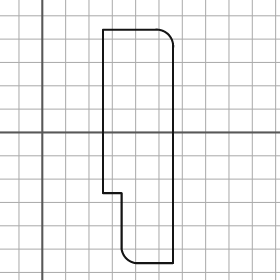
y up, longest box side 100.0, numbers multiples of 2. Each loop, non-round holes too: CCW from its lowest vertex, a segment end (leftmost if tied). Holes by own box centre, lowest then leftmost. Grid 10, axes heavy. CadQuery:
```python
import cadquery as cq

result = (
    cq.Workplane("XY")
    .moveTo(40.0, -56.0)
    .lineTo(56.0, -56.0)
    .lineTo(56.0, 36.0)
    .threePointArc((54.0, 42.0), (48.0, 44.0))
    .lineTo(26.0, 44.0)
    .lineTo(26.0, -26.0)
    .lineTo(34.0, -26.0)
    .lineTo(34.0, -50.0)
    .threePointArc((36.0, -54.0), (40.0, -56.0))
    .close()
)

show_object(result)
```